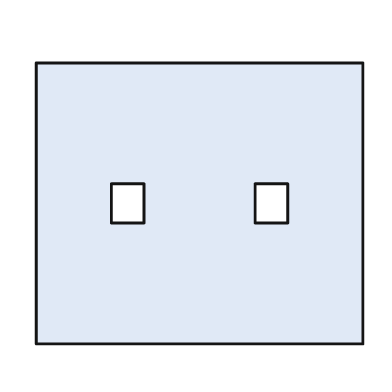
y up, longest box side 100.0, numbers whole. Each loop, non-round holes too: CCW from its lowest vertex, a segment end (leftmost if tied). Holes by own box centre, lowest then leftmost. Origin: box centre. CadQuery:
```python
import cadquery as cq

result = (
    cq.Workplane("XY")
    .moveTo(-50.0, -43.0)
    .lineTo(50.0, -43.0)
    .lineTo(50.0, 43.0)
    .lineTo(-50.0, 43.0)
    .close()
    .moveTo(-27.0, -6.0)
    .lineTo(-17.0, -6.0)
    .lineTo(-17.0, 6.0)
    .lineTo(-27.0, 6.0)
    .close()
    .moveTo(17.0, -6.0)
    .lineTo(27.0, -6.0)
    .lineTo(27.0, 6.0)
    .lineTo(17.0, 6.0)
    .close()
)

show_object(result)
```